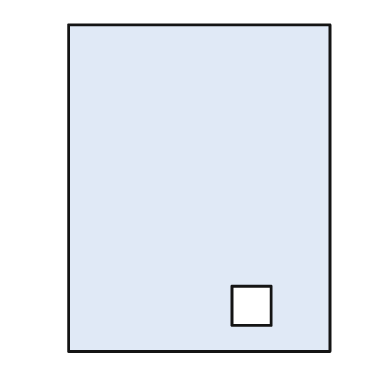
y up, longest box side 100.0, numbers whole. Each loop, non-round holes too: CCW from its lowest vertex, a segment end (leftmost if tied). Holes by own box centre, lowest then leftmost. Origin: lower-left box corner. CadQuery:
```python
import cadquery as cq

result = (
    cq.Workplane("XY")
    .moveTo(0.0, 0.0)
    .lineTo(80.0, 0.0)
    .lineTo(80.0, 100.0)
    .lineTo(0.0, 100.0)
    .close()
    .moveTo(50.0, 8.0)
    .lineTo(62.0, 8.0)
    .lineTo(62.0, 20.0)
    .lineTo(50.0, 20.0)
    .close()
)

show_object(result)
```